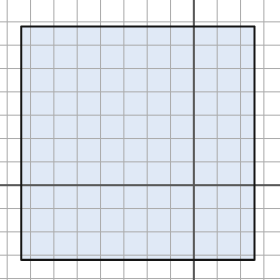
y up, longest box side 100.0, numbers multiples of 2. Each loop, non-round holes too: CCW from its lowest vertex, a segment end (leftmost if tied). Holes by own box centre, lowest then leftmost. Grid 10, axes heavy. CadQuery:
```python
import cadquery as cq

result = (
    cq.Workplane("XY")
    .moveTo(-74.0, -32.0)
    .lineTo(26.0, -32.0)
    .lineTo(26.0, 68.0)
    .lineTo(-74.0, 68.0)
    .close()
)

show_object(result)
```